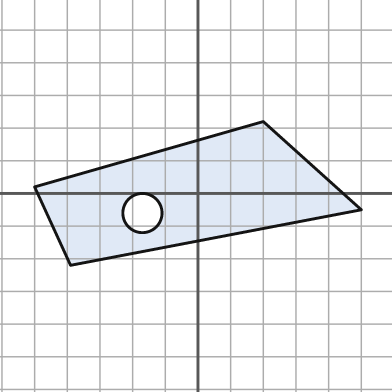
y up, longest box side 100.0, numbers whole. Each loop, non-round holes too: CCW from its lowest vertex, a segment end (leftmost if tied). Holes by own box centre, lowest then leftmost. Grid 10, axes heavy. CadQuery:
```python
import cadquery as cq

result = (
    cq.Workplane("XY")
    .moveTo(-39.0, -22.0)
    .lineTo(50.0, -5.0)
    .lineTo(20.0, 22.0)
    .lineTo(-50.0, 2.0)
    .close()
    .moveTo(-17.0, -6.0)
    .circle(6.0)
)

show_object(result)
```